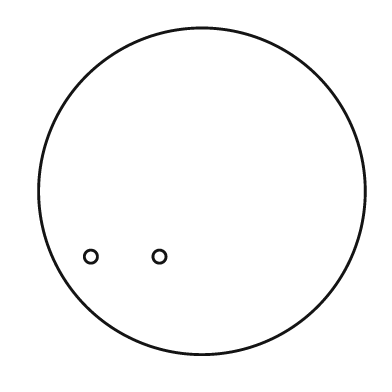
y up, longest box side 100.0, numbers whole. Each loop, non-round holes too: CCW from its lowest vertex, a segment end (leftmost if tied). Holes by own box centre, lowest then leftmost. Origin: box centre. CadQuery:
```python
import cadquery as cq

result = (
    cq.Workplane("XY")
    .moveTo(0.0, 0.0)
    .circle(50.0)
    .moveTo(-34.0, -20.0)
    .circle(2.0)
    .moveTo(-13.0, -20.0)
    .circle(2.0)
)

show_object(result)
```